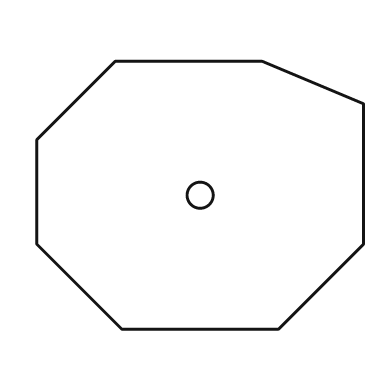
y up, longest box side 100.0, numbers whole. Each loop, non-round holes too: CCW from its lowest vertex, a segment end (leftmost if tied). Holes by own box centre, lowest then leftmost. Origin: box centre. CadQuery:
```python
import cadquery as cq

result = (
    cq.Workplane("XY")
    .moveTo(-24.0, -41.0)
    .lineTo(24.0, -41.0)
    .lineTo(50.0, -15.0)
    .lineTo(50.0, 28.0)
    .lineTo(19.0, 41.0)
    .lineTo(-26.0, 41.0)
    .lineTo(-50.0, 17.0)
    .lineTo(-50.0, -15.0)
    .close()
    .moveTo(0.0, 0.0)
    .circle(4.0)
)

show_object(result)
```